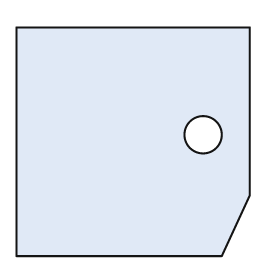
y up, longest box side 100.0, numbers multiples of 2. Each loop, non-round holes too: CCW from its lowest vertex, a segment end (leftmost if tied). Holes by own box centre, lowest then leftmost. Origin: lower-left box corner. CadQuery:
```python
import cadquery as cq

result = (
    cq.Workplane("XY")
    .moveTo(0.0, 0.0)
    .lineTo(88.0, 0.0)
    .lineTo(100.0, 26.0)
    .lineTo(100.0, 98.0)
    .lineTo(0.0, 98.0)
    .close()
    .moveTo(80.0, 52.0)
    .circle(8.0)
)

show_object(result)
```